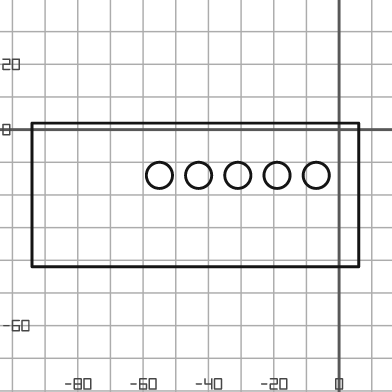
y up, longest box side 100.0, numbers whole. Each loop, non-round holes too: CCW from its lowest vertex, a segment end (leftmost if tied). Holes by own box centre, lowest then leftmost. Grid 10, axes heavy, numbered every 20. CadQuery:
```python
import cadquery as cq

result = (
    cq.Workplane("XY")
    .moveTo(-94.0, -42.0)
    .lineTo(6.0, -42.0)
    .lineTo(6.0, 2.0)
    .lineTo(-94.0, 2.0)
    .close()
    .moveTo(-55.0, -14.0)
    .circle(4.0)
    .moveTo(-43.0, -14.0)
    .circle(4.0)
    .moveTo(-31.0, -14.0)
    .circle(4.0)
    .moveTo(-19.0, -14.0)
    .circle(4.0)
    .moveTo(-7.0, -14.0)
    .circle(4.0)
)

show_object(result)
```